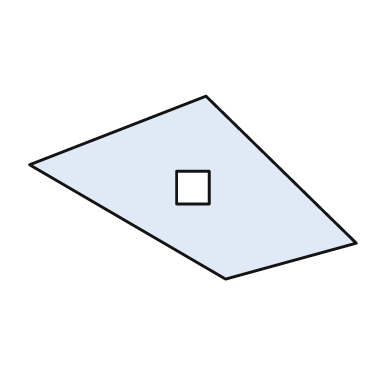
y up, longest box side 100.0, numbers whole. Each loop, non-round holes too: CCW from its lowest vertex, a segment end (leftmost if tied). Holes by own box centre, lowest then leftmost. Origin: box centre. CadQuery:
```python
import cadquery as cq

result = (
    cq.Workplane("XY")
    .moveTo(10.0, -28.0)
    .lineTo(50.0, -17.0)
    .lineTo(4.0, 28.0)
    .lineTo(-50.0, 7.0)
    .close()
    .moveTo(-5.0, -5.0)
    .lineTo(5.0, -5.0)
    .lineTo(5.0, 5.0)
    .lineTo(-5.0, 5.0)
    .close()
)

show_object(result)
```